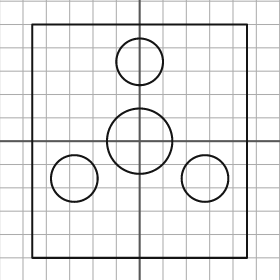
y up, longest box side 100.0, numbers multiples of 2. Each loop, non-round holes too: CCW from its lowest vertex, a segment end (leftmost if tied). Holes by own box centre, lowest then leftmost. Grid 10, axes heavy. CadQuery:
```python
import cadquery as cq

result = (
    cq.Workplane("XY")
    .moveTo(-46.0, -50.0)
    .lineTo(46.0, -50.0)
    .lineTo(46.0, 50.0)
    .lineTo(-46.0, 50.0)
    .close()
    .moveTo(-28.0, -16.0)
    .circle(10.0)
    .moveTo(28.0, -16.0)
    .circle(10.0)
    .moveTo(0.0, 0.0)
    .circle(14.0)
    .moveTo(0.0, 34.0)
    .circle(10.0)
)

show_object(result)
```